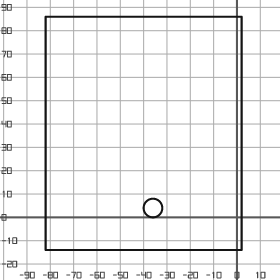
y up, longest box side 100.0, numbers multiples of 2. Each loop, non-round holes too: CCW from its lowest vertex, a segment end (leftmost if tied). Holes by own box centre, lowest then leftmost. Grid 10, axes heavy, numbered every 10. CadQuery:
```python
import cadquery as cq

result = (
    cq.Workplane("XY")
    .moveTo(-82.0, -14.0)
    .lineTo(2.0, -14.0)
    .lineTo(2.0, 86.0)
    .lineTo(-82.0, 86.0)
    .close()
    .moveTo(-36.0, 4.0)
    .circle(4.0)
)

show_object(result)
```